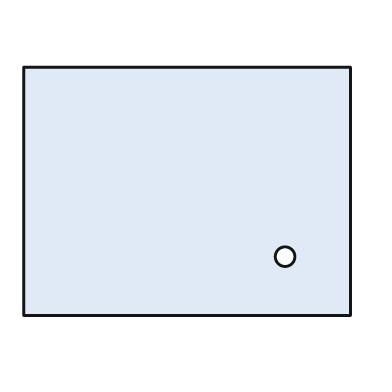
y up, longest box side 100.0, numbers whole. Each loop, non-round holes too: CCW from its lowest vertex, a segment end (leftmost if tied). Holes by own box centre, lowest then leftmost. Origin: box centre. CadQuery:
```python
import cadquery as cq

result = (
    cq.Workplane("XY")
    .moveTo(-50.0, -38.0)
    .lineTo(50.0, -38.0)
    .lineTo(50.0, 38.0)
    .lineTo(-50.0, 38.0)
    .close()
    .moveTo(30.0, -20.0)
    .circle(3.0)
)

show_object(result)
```